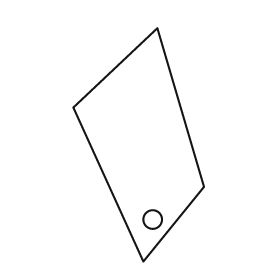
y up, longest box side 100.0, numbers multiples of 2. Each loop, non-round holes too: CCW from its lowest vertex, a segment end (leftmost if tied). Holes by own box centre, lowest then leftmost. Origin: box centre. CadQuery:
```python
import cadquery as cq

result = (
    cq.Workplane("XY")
    .moveTo(2.0, -50.0)
    .lineTo(28.0, -18.0)
    .lineTo(8.0, 50.0)
    .lineTo(-28.0, 16.0)
    .close()
    .moveTo(6.0, -32.0)
    .circle(4.0)
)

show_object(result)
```